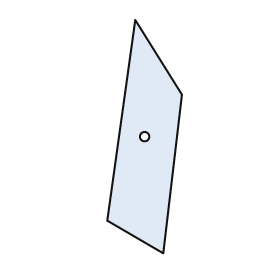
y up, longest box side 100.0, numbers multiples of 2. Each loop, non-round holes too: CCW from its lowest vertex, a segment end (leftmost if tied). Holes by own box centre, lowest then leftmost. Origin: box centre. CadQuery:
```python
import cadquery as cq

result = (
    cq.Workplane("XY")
    .moveTo(8.0, -50.0)
    .lineTo(16.0, 18.0)
    .lineTo(-4.0, 50.0)
    .lineTo(-16.0, -36.0)
    .close()
    .moveTo(0.0, 0.0)
    .circle(2.0)
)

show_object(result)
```